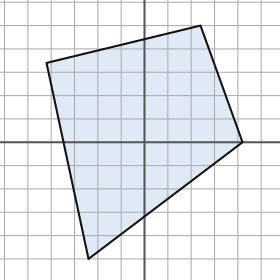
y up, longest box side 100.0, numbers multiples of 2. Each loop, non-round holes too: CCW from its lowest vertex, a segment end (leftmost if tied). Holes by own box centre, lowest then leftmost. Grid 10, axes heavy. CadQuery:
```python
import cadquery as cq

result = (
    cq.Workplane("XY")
    .moveTo(-24.0, -50.0)
    .lineTo(42.0, 0.0)
    .lineTo(24.0, 50.0)
    .lineTo(-42.0, 34.0)
    .close()
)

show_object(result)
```